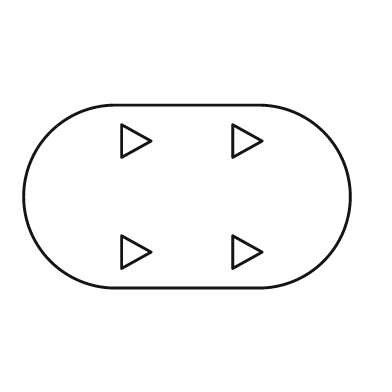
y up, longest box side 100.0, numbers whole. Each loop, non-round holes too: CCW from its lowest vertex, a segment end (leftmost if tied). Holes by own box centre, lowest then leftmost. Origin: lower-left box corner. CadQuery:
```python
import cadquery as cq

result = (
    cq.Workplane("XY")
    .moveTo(28.0, 0.0)
    .lineTo(72.0, 0.0)
    .threePointArc((100.0, 28.0), (72.0, 56.0))
    .lineTo(28.0, 56.0)
    .threePointArc((0.0, 28.0), (28.0, 0.0))
    .close()
    .moveTo(30.0, 6.0)
    .lineTo(39.0, 11.0)
    .lineTo(30.0, 16.0)
    .close()
    .moveTo(64.0, 6.0)
    .lineTo(73.0, 11.0)
    .lineTo(64.0, 16.0)
    .close()
    .moveTo(30.0, 40.0)
    .lineTo(39.0, 45.0)
    .lineTo(30.0, 50.0)
    .close()
    .moveTo(64.0, 40.0)
    .lineTo(73.0, 45.0)
    .lineTo(64.0, 50.0)
    .close()
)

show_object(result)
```